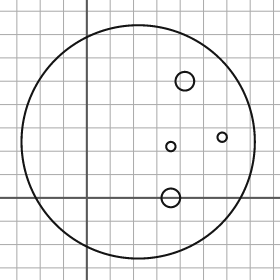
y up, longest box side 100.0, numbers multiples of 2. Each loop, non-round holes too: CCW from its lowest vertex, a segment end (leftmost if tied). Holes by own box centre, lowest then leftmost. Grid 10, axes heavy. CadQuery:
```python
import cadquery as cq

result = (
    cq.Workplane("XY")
    .moveTo(22.0, 24.0)
    .circle(50.0)
    .moveTo(36.0, 0.0)
    .circle(4.0)
    .moveTo(36.0, 22.0)
    .circle(2.0)
    .moveTo(58.0, 26.0)
    .circle(2.0)
    .moveTo(42.0, 50.0)
    .circle(4.0)
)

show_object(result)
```